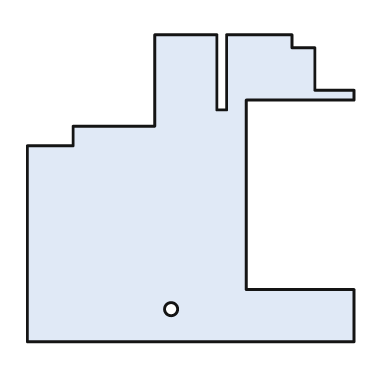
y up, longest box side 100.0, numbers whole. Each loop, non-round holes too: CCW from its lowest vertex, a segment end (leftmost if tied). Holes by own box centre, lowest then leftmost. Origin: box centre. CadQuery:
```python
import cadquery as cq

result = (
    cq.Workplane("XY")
    .moveTo(-50.0, -47.0)
    .lineTo(50.0, -47.0)
    .lineTo(50.0, -31.0)
    .lineTo(17.0, -31.0)
    .lineTo(17.0, 27.0)
    .lineTo(50.0, 27.0)
    .lineTo(50.0, 30.0)
    .lineTo(38.0, 30.0)
    .lineTo(38.0, 43.0)
    .lineTo(31.0, 43.0)
    .lineTo(31.0, 47.0)
    .lineTo(11.0, 47.0)
    .lineTo(11.0, 24.0)
    .lineTo(8.0, 24.0)
    .lineTo(8.0, 47.0)
    .lineTo(-11.0, 47.0)
    .lineTo(-11.0, 19.0)
    .lineTo(-36.0, 19.0)
    .lineTo(-36.0, 13.0)
    .lineTo(-50.0, 13.0)
    .close()
    .moveTo(-6.0, -37.0)
    .circle(2.0)
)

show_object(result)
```